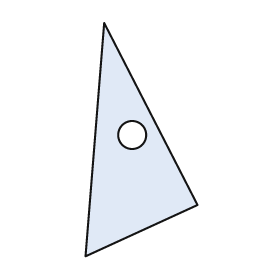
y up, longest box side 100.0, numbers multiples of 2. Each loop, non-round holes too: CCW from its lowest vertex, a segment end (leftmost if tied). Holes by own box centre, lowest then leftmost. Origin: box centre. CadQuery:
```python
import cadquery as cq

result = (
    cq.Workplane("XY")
    .moveTo(-24.0, -50.0)
    .lineTo(24.0, -28.0)
    .lineTo(-16.0, 50.0)
    .close()
    .moveTo(-4.0, 2.0)
    .circle(6.0)
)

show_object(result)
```